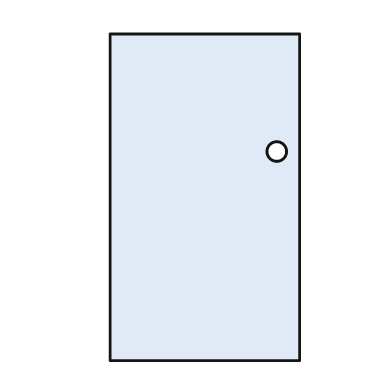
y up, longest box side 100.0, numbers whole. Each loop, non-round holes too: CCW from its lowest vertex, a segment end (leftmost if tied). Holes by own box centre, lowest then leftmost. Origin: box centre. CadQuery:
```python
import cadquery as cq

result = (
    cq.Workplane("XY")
    .moveTo(-29.0, -50.0)
    .lineTo(29.0, -50.0)
    .lineTo(29.0, 50.0)
    .lineTo(-29.0, 50.0)
    .close()
    .moveTo(22.0, 14.0)
    .circle(3.0)
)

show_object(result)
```